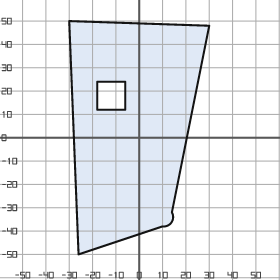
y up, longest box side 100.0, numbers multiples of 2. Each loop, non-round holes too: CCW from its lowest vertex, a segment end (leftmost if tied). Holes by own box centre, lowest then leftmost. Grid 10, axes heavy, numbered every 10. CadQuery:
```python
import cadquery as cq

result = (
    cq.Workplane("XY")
    .moveTo(-26.0, -50.0)
    .lineTo(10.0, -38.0)
    .threePointArc((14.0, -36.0), (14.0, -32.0))
    .lineTo(30.0, 48.0)
    .lineTo(-30.0, 50.0)
    .close()
    .moveTo(-18.0, 12.0)
    .lineTo(-6.0, 12.0)
    .lineTo(-6.0, 24.0)
    .lineTo(-18.0, 24.0)
    .close()
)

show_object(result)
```